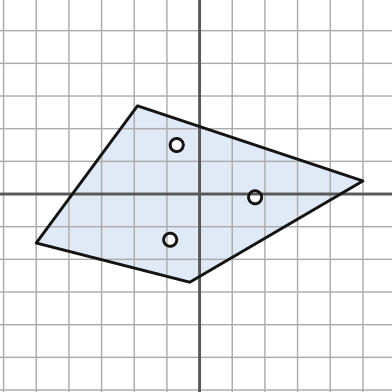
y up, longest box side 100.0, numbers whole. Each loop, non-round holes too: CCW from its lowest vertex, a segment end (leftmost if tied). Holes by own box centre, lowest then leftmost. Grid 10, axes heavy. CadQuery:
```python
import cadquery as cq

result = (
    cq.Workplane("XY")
    .moveTo(-3.0, -27.0)
    .lineTo(50.0, 4.0)
    .lineTo(-19.0, 27.0)
    .lineTo(-50.0, -15.0)
    .close()
    .moveTo(-9.0, -14.0)
    .circle(2.0)
    .moveTo(17.0, -1.0)
    .circle(2.0)
    .moveTo(-7.0, 15.0)
    .circle(2.0)
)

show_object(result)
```